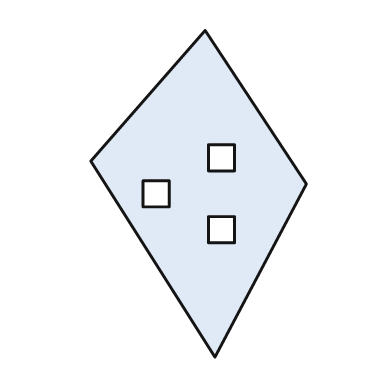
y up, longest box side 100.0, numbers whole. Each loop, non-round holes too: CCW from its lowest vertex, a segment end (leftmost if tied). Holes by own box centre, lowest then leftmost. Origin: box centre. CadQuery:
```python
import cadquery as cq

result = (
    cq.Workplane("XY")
    .moveTo(5.0, -50.0)
    .lineTo(33.0, 3.0)
    .lineTo(2.0, 50.0)
    .lineTo(-33.0, 10.0)
    .close()
    .moveTo(3.0, -15.0)
    .lineTo(11.0, -15.0)
    .lineTo(11.0, -7.0)
    .lineTo(3.0, -7.0)
    .close()
    .moveTo(-17.0, -4.0)
    .lineTo(-9.0, -4.0)
    .lineTo(-9.0, 4.0)
    .lineTo(-17.0, 4.0)
    .close()
    .moveTo(3.0, 7.0)
    .lineTo(11.0, 7.0)
    .lineTo(11.0, 15.0)
    .lineTo(3.0, 15.0)
    .close()
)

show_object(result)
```